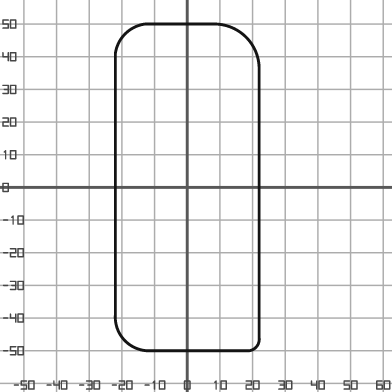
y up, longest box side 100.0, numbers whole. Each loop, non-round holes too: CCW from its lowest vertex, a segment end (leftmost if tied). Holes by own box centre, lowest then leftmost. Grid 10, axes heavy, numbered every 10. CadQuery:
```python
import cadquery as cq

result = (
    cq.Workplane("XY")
    .moveTo(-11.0, -50.0)
    .lineTo(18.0, -50.0)
    .threePointArc((21.0, -49.0), (22.0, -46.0))
    .lineTo(22.0, 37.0)
    .threePointArc((18.0, 46.0), (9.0, 50.0))
    .lineTo(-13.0, 50.0)
    .threePointArc((-19.0, 47.0), (-22.0, 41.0))
    .lineTo(-22.0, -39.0)
    .threePointArc((-19.0, -47.0), (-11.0, -50.0))
    .close()
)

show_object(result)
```